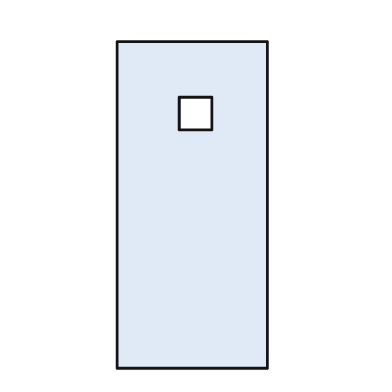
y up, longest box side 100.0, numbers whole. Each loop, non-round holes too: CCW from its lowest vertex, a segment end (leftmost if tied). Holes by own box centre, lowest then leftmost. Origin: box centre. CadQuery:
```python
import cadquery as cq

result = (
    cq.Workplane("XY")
    .moveTo(-23.0, -50.0)
    .lineTo(23.0, -50.0)
    .lineTo(23.0, 50.0)
    .lineTo(-23.0, 50.0)
    .close()
    .moveTo(-4.0, 23.0)
    .lineTo(6.0, 23.0)
    .lineTo(6.0, 33.0)
    .lineTo(-4.0, 33.0)
    .close()
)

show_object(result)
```